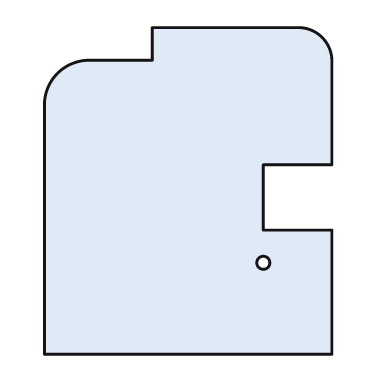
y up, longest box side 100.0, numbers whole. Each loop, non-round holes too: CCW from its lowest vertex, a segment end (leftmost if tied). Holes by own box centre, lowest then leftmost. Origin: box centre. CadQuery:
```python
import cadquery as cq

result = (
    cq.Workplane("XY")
    .moveTo(-44.0, -50.0)
    .lineTo(44.0, -50.0)
    .lineTo(44.0, -12.0)
    .lineTo(23.0, -12.0)
    .lineTo(23.0, 8.0)
    .lineTo(44.0, 8.0)
    .lineTo(44.0, 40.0)
    .threePointArc((41.0, 47.0), (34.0, 50.0))
    .lineTo(-11.0, 50.0)
    .lineTo(-11.0, 40.0)
    .lineTo(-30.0, 40.0)
    .threePointArc((-40.0, 36.0), (-44.0, 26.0))
    .close()
    .moveTo(23.0, -22.0)
    .circle(2.0)
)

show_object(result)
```